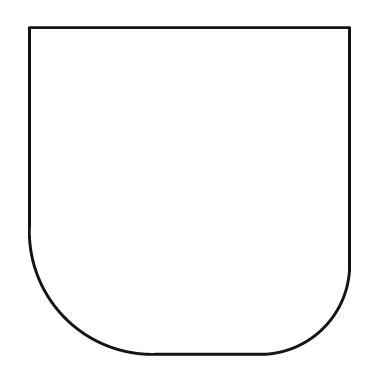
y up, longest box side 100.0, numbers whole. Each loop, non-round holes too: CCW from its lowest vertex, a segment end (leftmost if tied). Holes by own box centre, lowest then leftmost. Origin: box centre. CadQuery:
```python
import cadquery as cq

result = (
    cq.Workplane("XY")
    .moveTo(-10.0, -50.0)
    .lineTo(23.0, -50.0)
    .threePointArc((41.0, -42.0), (49.0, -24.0))
    .lineTo(49.0, 50.0)
    .lineTo(-49.0, 50.0)
    .lineTo(-49.0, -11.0)
    .threePointArc((-38.0, -39.0), (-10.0, -50.0))
    .close()
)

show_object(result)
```